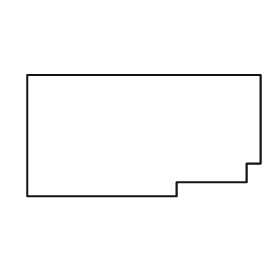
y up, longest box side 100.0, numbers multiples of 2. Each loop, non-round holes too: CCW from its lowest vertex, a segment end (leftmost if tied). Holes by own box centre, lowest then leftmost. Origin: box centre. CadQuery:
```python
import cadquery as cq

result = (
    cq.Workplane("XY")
    .moveTo(-50.0, -26.0)
    .lineTo(14.0, -26.0)
    .lineTo(14.0, -20.0)
    .lineTo(44.0, -20.0)
    .lineTo(44.0, -12.0)
    .lineTo(50.0, -12.0)
    .lineTo(50.0, 26.0)
    .lineTo(-50.0, 26.0)
    .close()
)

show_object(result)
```